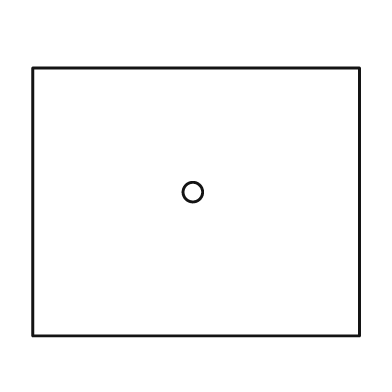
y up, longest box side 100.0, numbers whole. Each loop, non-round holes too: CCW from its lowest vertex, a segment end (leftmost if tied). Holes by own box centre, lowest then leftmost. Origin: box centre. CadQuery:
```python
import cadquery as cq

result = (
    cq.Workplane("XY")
    .moveTo(-50.0, -41.0)
    .lineTo(50.0, -41.0)
    .lineTo(50.0, 41.0)
    .lineTo(-50.0, 41.0)
    .close()
    .moveTo(-1.0, 3.0)
    .circle(3.0)
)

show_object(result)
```